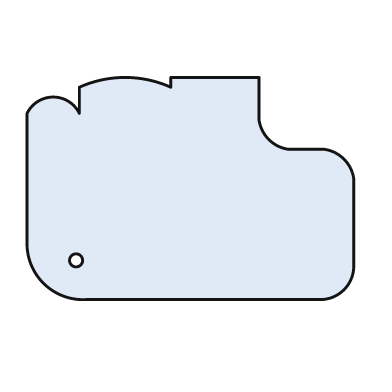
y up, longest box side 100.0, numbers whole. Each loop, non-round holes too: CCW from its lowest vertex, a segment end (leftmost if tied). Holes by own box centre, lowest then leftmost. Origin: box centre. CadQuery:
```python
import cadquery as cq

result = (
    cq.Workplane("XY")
    .moveTo(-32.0, -34.0)
    .lineTo(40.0, -34.0)
    .threePointArc((47.0, -31.0), (50.0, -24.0))
    .lineTo(50.0, 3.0)
    .threePointArc((47.0, 9.0), (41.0, 12.0))
    .lineTo(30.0, 12.0)
    .threePointArc((24.0, 15.0), (21.0, 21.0))
    .lineTo(21.0, 34.0)
    .lineTo(-6.0, 34.0)
    .lineTo(-6.0, 31.0)
    .threePointArc((-20.0, 34.0), (-34.0, 31.0))
    .lineTo(-34.0, 23.0)
    .threePointArc((-42.0, 28.0), (-50.0, 23.0))
    .lineTo(-50.0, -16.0)
    .threePointArc((-45.0, -29.0), (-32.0, -34.0))
    .close()
    .moveTo(-35.0, -22.0)
    .circle(2.0)
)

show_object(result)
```